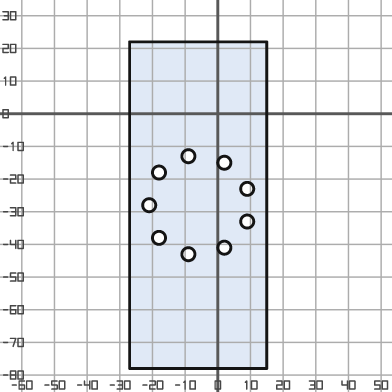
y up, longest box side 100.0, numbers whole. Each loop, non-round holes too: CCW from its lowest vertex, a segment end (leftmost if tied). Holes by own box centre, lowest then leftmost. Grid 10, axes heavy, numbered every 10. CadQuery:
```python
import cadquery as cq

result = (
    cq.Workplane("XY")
    .moveTo(-27.0, -78.0)
    .lineTo(15.0, -78.0)
    .lineTo(15.0, 22.0)
    .lineTo(-27.0, 22.0)
    .close()
    .moveTo(-9.0, -43.0)
    .circle(2.0)
    .moveTo(2.0, -41.0)
    .circle(2.0)
    .moveTo(-18.0, -38.0)
    .circle(2.0)
    .moveTo(9.0, -33.0)
    .circle(2.0)
    .moveTo(-21.0, -28.0)
    .circle(2.0)
    .moveTo(9.0, -23.0)
    .circle(2.0)
    .moveTo(-18.0, -18.0)
    .circle(2.0)
    .moveTo(2.0, -15.0)
    .circle(2.0)
    .moveTo(-9.0, -13.0)
    .circle(2.0)
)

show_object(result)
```